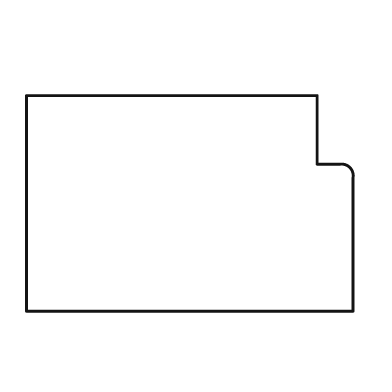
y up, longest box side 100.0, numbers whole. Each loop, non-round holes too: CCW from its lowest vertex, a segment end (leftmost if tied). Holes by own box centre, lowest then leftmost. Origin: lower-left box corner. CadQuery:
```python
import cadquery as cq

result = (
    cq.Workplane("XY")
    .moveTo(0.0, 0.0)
    .lineTo(100.0, 0.0)
    .lineTo(100.0, 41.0)
    .threePointArc((99.0, 44.0), (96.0, 45.0))
    .lineTo(89.0, 45.0)
    .lineTo(89.0, 66.0)
    .lineTo(0.0, 66.0)
    .close()
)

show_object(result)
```